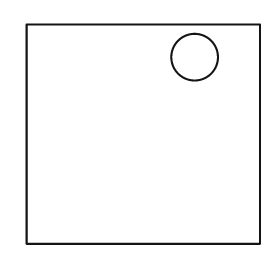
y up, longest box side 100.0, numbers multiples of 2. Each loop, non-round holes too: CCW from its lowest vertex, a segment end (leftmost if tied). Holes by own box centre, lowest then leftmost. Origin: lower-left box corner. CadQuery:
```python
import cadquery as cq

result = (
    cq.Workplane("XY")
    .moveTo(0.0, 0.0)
    .lineTo(100.0, 0.0)
    .lineTo(100.0, 94.0)
    .lineTo(0.0, 94.0)
    .close()
    .moveTo(72.0, 80.0)
    .circle(10.0)
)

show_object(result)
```